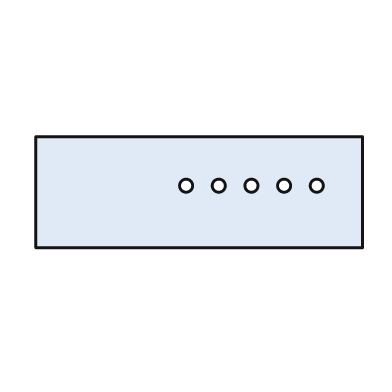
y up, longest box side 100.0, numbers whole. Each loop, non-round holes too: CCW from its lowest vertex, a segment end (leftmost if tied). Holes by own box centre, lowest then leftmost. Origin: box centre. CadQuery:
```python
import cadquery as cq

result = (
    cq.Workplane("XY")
    .moveTo(-50.0, -17.0)
    .lineTo(50.0, -17.0)
    .lineTo(50.0, 17.0)
    .lineTo(-50.0, 17.0)
    .close()
    .moveTo(-4.0, 2.0)
    .circle(2.0)
    .moveTo(6.0, 2.0)
    .circle(2.0)
    .moveTo(16.0, 2.0)
    .circle(2.0)
    .moveTo(26.0, 2.0)
    .circle(2.0)
    .moveTo(36.0, 2.0)
    .circle(2.0)
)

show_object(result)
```